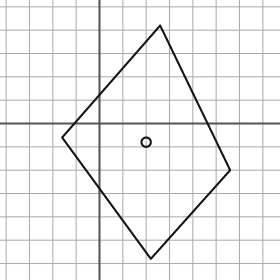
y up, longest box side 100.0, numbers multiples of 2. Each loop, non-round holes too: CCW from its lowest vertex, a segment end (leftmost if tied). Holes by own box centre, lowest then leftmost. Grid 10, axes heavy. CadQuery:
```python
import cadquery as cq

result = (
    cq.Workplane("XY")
    .moveTo(22.0, -58.0)
    .lineTo(56.0, -20.0)
    .lineTo(26.0, 42.0)
    .lineTo(-16.0, -6.0)
    .close()
    .moveTo(20.0, -8.0)
    .circle(2.0)
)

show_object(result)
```